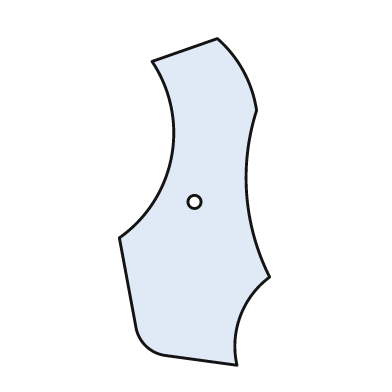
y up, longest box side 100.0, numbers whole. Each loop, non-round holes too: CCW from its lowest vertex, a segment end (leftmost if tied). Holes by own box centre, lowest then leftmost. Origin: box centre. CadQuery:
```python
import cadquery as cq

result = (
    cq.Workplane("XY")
    .moveTo(13.0, -50.0)
    .threePointArc((14.0, -35.0), (23.0, -23.0))
    .threePointArc((16.0, 2.0), (19.0, 28.0))
    .threePointArc((15.0, 40.0), (7.0, 50.0))
    .lineTo(-13.0, 43.0)
    .threePointArc((-7.0, 14.0), (-23.0, -11.0))
    .lineTo(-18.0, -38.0)
    .threePointArc((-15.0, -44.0), (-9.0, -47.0))
    .close()
    .moveTo(0.0, 0.0)
    .circle(2.0)
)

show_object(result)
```